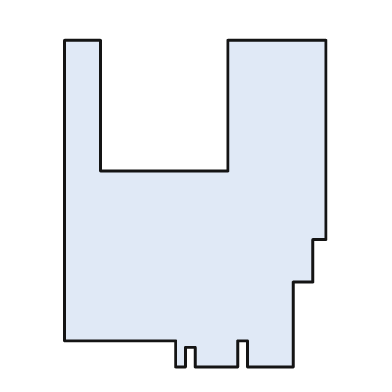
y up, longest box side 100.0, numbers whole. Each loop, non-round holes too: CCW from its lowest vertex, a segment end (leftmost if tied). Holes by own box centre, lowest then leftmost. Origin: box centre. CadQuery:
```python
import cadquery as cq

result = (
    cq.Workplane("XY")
    .moveTo(-6.0, -50.0)
    .lineTo(-3.0, -50.0)
    .lineTo(-3.0, -44.0)
    .lineTo(0.0, -44.0)
    .lineTo(0.0, -50.0)
    .lineTo(13.0, -50.0)
    .lineTo(13.0, -42.0)
    .lineTo(16.0, -42.0)
    .lineTo(16.0, -50.0)
    .lineTo(30.0, -50.0)
    .lineTo(30.0, -24.0)
    .lineTo(36.0, -24.0)
    .lineTo(36.0, -11.0)
    .lineTo(40.0, -11.0)
    .lineTo(40.0, 50.0)
    .lineTo(10.0, 50.0)
    .lineTo(10.0, 10.0)
    .lineTo(-29.0, 10.0)
    .lineTo(-29.0, 50.0)
    .lineTo(-40.0, 50.0)
    .lineTo(-40.0, -42.0)
    .lineTo(-6.0, -42.0)
    .close()
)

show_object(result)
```